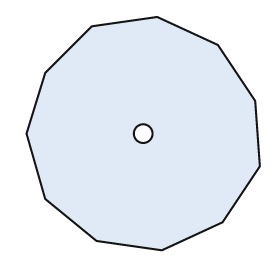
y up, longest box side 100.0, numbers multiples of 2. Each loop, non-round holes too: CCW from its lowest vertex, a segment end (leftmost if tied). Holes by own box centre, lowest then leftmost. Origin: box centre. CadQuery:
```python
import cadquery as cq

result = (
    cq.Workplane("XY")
    .moveTo(8.0, -50.0)
    .lineTo(34.0, -38.0)
    .lineTo(50.0, -14.0)
    .lineTo(48.0, 14.0)
    .lineTo(32.0, 38.0)
    .lineTo(6.0, 50.0)
    .lineTo(-22.0, 46.0)
    .lineTo(-42.0, 26.0)
    .lineTo(-50.0, 0.0)
    .lineTo(-42.0, -28.0)
    .lineTo(-20.0, -46.0)
    .close()
    .moveTo(0.0, 0.0)
    .circle(4.0)
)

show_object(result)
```